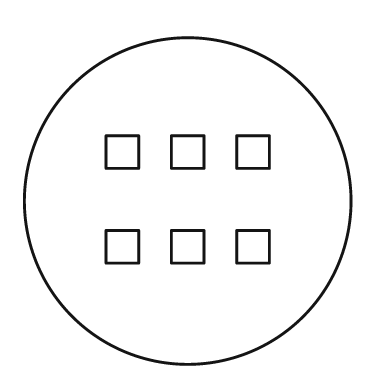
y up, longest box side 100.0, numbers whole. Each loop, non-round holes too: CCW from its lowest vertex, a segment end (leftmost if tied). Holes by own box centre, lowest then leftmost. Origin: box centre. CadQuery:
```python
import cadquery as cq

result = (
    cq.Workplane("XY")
    .moveTo(0.0, 0.0)
    .circle(50.0)
    .moveTo(-25.0, -19.0)
    .lineTo(-15.0, -19.0)
    .lineTo(-15.0, -9.0)
    .lineTo(-25.0, -9.0)
    .close()
    .moveTo(-5.0, -19.0)
    .lineTo(5.0, -19.0)
    .lineTo(5.0, -9.0)
    .lineTo(-5.0, -9.0)
    .close()
    .moveTo(15.0, -19.0)
    .lineTo(25.0, -19.0)
    .lineTo(25.0, -9.0)
    .lineTo(15.0, -9.0)
    .close()
    .moveTo(-25.0, 10.0)
    .lineTo(-15.0, 10.0)
    .lineTo(-15.0, 20.0)
    .lineTo(-25.0, 20.0)
    .close()
    .moveTo(-5.0, 10.0)
    .lineTo(5.0, 10.0)
    .lineTo(5.0, 20.0)
    .lineTo(-5.0, 20.0)
    .close()
    .moveTo(15.0, 10.0)
    .lineTo(25.0, 10.0)
    .lineTo(25.0, 20.0)
    .lineTo(15.0, 20.0)
    .close()
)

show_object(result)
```